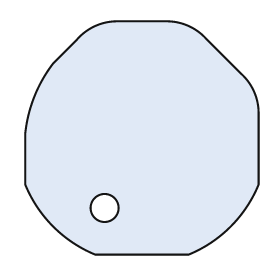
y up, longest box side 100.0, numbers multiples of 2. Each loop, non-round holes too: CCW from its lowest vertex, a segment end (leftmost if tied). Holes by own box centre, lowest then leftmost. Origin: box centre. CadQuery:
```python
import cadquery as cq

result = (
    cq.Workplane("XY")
    .moveTo(-20.0, -50.0)
    .lineTo(20.0, -50.0)
    .threePointArc((38.0, -38.0), (50.0, -20.0))
    .lineTo(50.0, 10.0)
    .threePointArc((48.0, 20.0), (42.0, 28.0))
    .lineTo(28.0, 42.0)
    .threePointArc((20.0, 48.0), (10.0, 50.0))
    .lineTo(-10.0, 50.0)
    .threePointArc((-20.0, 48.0), (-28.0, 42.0))
    .lineTo(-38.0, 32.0)
    .threePointArc((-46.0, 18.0), (-50.0, 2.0))
    .lineTo(-50.0, -20.0)
    .threePointArc((-38.0, -38.0), (-20.0, -50.0))
    .close()
    .moveTo(-16.0, -30.0)
    .circle(6.0)
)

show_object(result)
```